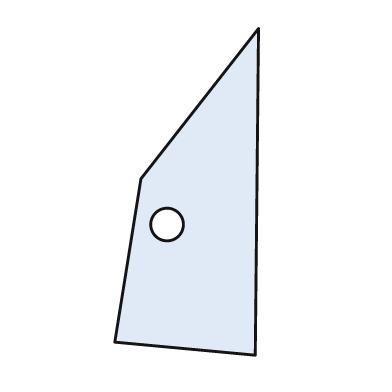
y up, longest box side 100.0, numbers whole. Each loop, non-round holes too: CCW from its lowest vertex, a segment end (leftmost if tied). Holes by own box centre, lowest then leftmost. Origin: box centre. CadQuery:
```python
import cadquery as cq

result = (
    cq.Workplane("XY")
    .moveTo(21.0, -50.0)
    .lineTo(22.0, 50.0)
    .lineTo(-14.0, 4.0)
    .lineTo(-22.0, -46.0)
    .close()
    .moveTo(-6.0, -10.0)
    .circle(5.0)
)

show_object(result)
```